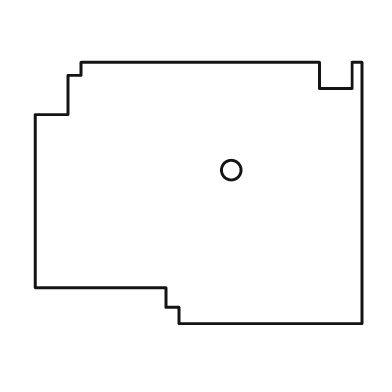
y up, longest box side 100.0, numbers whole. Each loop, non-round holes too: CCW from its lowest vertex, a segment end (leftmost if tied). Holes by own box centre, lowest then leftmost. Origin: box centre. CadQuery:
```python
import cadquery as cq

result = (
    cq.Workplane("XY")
    .moveTo(-6.0, -40.0)
    .lineTo(50.0, -40.0)
    .lineTo(50.0, 40.0)
    .lineTo(47.0, 40.0)
    .lineTo(47.0, 32.0)
    .lineTo(37.0, 32.0)
    .lineTo(37.0, 40.0)
    .lineTo(-36.0, 40.0)
    .lineTo(-36.0, 36.0)
    .lineTo(-40.0, 36.0)
    .lineTo(-40.0, 24.0)
    .lineTo(-50.0, 24.0)
    .lineTo(-50.0, -29.0)
    .lineTo(-10.0, -29.0)
    .lineTo(-10.0, -35.0)
    .lineTo(-6.0, -35.0)
    .close()
    .moveTo(10.0, 7.0)
    .circle(3.0)
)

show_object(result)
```